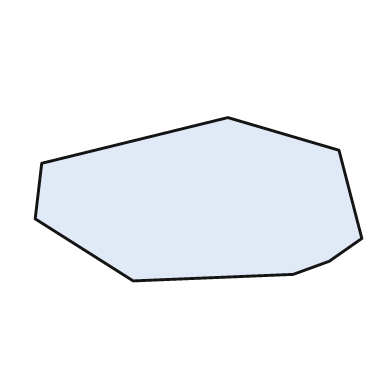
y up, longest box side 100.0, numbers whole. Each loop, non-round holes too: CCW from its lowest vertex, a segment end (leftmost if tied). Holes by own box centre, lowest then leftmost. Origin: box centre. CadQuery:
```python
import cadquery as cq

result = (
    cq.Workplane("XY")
    .moveTo(-20.0, -25.0)
    .lineTo(29.0, -23.0)
    .lineTo(40.0, -19.0)
    .lineTo(50.0, -12.0)
    .lineTo(43.0, 15.0)
    .lineTo(9.0, 25.0)
    .lineTo(-48.0, 11.0)
    .lineTo(-50.0, -6.0)
    .close()
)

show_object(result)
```